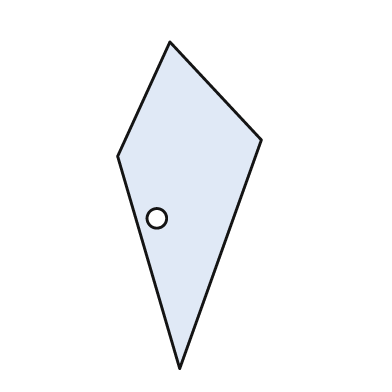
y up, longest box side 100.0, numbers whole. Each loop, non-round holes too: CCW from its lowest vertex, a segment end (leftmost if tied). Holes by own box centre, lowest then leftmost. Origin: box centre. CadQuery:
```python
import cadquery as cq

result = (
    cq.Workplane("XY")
    .moveTo(-3.0, -50.0)
    .lineTo(22.0, 20.0)
    .lineTo(-6.0, 50.0)
    .lineTo(-22.0, 15.0)
    .close()
    .moveTo(-10.0, -4.0)
    .circle(3.0)
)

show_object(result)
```